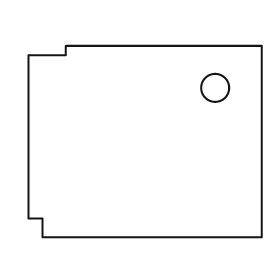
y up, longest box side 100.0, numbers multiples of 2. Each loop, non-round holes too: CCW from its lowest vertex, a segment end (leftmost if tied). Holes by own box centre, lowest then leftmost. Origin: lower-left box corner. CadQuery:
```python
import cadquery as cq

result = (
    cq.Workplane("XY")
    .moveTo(6.0, 0.0)
    .lineTo(100.0, 0.0)
    .lineTo(100.0, 82.0)
    .lineTo(16.0, 82.0)
    .lineTo(16.0, 78.0)
    .lineTo(0.0, 78.0)
    .lineTo(0.0, 8.0)
    .lineTo(6.0, 8.0)
    .close()
    .moveTo(80.0, 64.0)
    .circle(6.0)
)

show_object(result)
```